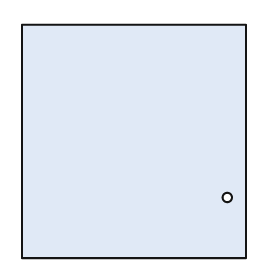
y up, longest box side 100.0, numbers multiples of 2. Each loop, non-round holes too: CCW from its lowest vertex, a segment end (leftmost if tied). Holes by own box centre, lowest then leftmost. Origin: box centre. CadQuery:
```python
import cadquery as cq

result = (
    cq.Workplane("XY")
    .moveTo(-48.0, -50.0)
    .lineTo(48.0, -50.0)
    .lineTo(48.0, 50.0)
    .lineTo(-48.0, 50.0)
    .close()
    .moveTo(40.0, -24.0)
    .circle(2.0)
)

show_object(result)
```